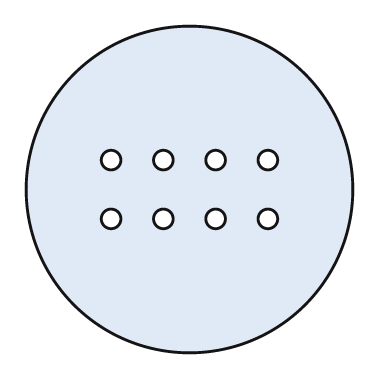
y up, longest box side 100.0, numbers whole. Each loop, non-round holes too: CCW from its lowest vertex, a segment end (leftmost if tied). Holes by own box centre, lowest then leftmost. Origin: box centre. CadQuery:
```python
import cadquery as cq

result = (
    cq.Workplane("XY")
    .moveTo(0.0, 0.0)
    .circle(50.0)
    .moveTo(-24.0, -9.0)
    .circle(3.0)
    .moveTo(-8.0, -9.0)
    .circle(3.0)
    .moveTo(8.0, -9.0)
    .circle(3.0)
    .moveTo(24.0, -9.0)
    .circle(3.0)
    .moveTo(-24.0, 9.0)
    .circle(3.0)
    .moveTo(-8.0, 9.0)
    .circle(3.0)
    .moveTo(8.0, 9.0)
    .circle(3.0)
    .moveTo(24.0, 9.0)
    .circle(3.0)
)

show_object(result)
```